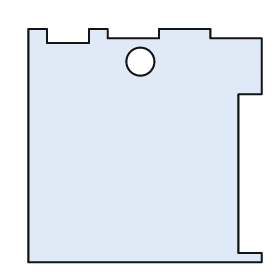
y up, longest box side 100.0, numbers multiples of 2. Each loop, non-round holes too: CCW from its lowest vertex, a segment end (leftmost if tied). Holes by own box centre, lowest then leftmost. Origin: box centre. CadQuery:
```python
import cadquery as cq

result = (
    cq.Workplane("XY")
    .moveTo(-50.0, -50.0)
    .lineTo(50.0, -50.0)
    .lineTo(50.0, -46.0)
    .lineTo(40.0, -46.0)
    .lineTo(40.0, 22.0)
    .lineTo(50.0, 22.0)
    .lineTo(50.0, 46.0)
    .lineTo(28.0, 46.0)
    .lineTo(28.0, 50.0)
    .lineTo(6.0, 50.0)
    .lineTo(6.0, 46.0)
    .lineTo(-16.0, 46.0)
    .lineTo(-16.0, 50.0)
    .lineTo(-24.0, 50.0)
    .lineTo(-24.0, 44.0)
    .lineTo(-42.0, 44.0)
    .lineTo(-42.0, 50.0)
    .lineTo(-50.0, 50.0)
    .close()
    .moveTo(-2.0, 36.0)
    .circle(6.0)
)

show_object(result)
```